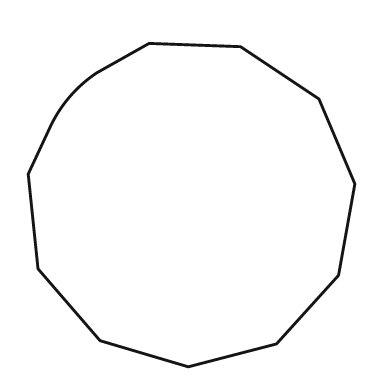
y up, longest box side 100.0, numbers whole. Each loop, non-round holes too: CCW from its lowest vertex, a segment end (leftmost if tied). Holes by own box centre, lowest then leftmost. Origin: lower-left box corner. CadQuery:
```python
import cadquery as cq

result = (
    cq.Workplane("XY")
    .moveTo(49.0, 0.0)
    .lineTo(76.0, 7.0)
    .lineTo(95.0, 28.0)
    .lineTo(100.0, 56.0)
    .lineTo(89.0, 82.0)
    .lineTo(65.0, 98.0)
    .lineTo(37.0, 99.0)
    .lineTo(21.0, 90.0)
    .threePointArc((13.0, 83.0), (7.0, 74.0))
    .lineTo(0.0, 59.0)
    .lineTo(3.0, 30.0)
    .lineTo(22.0, 8.0)
    .close()
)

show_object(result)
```